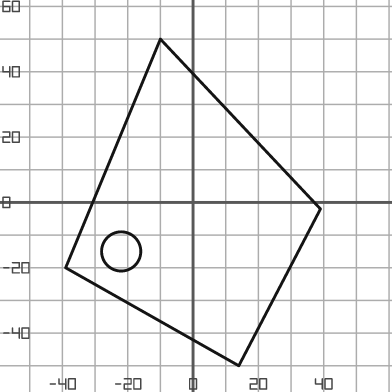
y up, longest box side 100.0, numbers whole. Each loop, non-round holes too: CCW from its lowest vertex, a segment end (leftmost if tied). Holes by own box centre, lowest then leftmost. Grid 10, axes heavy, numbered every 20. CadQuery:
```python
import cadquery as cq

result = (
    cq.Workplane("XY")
    .moveTo(14.0, -50.0)
    .lineTo(39.0, -2.0)
    .lineTo(-10.0, 50.0)
    .lineTo(-39.0, -20.0)
    .close()
    .moveTo(-22.0, -15.0)
    .circle(6.0)
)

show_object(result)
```